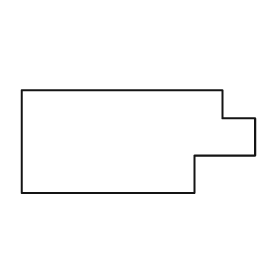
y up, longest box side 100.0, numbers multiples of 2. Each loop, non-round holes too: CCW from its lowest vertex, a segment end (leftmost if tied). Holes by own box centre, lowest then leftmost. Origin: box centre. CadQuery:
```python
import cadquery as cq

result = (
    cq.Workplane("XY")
    .moveTo(-50.0, -22.0)
    .lineTo(24.0, -22.0)
    .lineTo(24.0, -6.0)
    .lineTo(50.0, -6.0)
    .lineTo(50.0, 10.0)
    .lineTo(36.0, 10.0)
    .lineTo(36.0, 22.0)
    .lineTo(-50.0, 22.0)
    .close()
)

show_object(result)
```